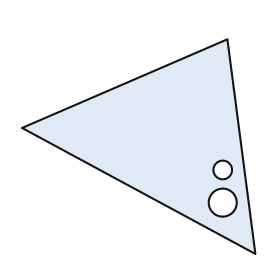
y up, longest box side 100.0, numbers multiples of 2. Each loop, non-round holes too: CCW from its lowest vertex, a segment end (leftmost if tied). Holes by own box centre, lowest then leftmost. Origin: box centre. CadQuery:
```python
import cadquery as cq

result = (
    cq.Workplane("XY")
    .moveTo(50.0, -46.0)
    .lineTo(38.0, 46.0)
    .lineTo(-50.0, 8.0)
    .close()
    .moveTo(36.0, -24.0)
    .circle(6.0)
    .moveTo(36.0, -10.0)
    .circle(4.0)
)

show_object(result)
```